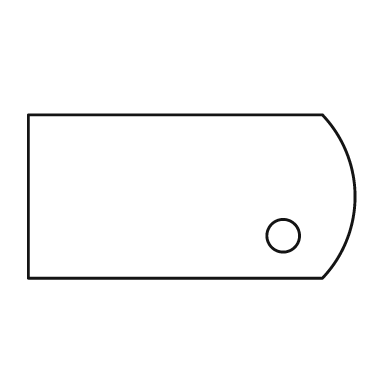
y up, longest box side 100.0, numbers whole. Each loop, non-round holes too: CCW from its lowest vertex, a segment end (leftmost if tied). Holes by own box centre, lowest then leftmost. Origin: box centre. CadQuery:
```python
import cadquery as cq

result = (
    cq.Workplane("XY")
    .moveTo(-50.0, -25.0)
    .lineTo(40.0, -25.0)
    .threePointArc((50.0, 0.0), (40.0, 25.0))
    .lineTo(-50.0, 25.0)
    .close()
    .moveTo(28.0, -12.0)
    .circle(5.0)
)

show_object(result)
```